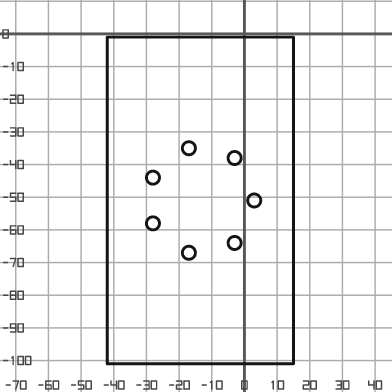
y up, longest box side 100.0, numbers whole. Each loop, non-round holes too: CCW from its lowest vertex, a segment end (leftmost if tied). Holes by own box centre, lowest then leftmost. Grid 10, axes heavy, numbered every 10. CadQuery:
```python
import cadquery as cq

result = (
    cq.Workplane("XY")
    .moveTo(-42.0, -101.0)
    .lineTo(15.0, -101.0)
    .lineTo(15.0, -1.0)
    .lineTo(-42.0, -1.0)
    .close()
    .moveTo(-17.0, -67.0)
    .circle(2.0)
    .moveTo(-3.0, -64.0)
    .circle(2.0)
    .moveTo(-28.0, -58.0)
    .circle(2.0)
    .moveTo(3.0, -51.0)
    .circle(2.0)
    .moveTo(-28.0, -44.0)
    .circle(2.0)
    .moveTo(-3.0, -38.0)
    .circle(2.0)
    .moveTo(-17.0, -35.0)
    .circle(2.0)
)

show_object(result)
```